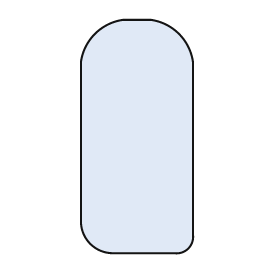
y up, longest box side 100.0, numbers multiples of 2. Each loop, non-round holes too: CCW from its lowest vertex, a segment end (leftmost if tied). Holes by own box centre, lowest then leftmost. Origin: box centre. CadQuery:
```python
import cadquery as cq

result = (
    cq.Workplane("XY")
    .moveTo(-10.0, -50.0)
    .lineTo(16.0, -50.0)
    .threePointArc((22.0, -48.0), (24.0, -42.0))
    .lineTo(24.0, 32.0)
    .threePointArc((18.0, 44.0), (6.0, 50.0))
    .lineTo(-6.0, 50.0)
    .threePointArc((-18.0, 44.0), (-24.0, 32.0))
    .lineTo(-24.0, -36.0)
    .threePointArc((-20.0, -46.0), (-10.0, -50.0))
    .close()
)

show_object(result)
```